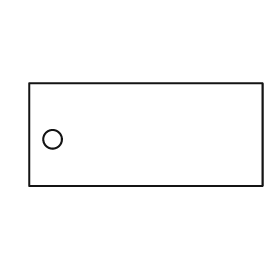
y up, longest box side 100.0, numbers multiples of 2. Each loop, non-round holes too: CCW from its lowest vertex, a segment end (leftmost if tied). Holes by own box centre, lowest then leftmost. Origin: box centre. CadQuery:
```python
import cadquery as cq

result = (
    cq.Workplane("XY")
    .moveTo(-50.0, -22.0)
    .lineTo(50.0, -22.0)
    .lineTo(50.0, 22.0)
    .lineTo(-50.0, 22.0)
    .close()
    .moveTo(-40.0, -2.0)
    .circle(4.0)
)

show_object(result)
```